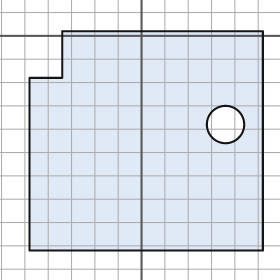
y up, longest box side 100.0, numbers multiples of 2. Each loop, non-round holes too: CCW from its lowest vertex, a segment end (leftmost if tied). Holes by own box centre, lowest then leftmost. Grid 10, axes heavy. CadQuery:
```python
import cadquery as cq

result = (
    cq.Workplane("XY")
    .moveTo(-48.0, -92.0)
    .lineTo(52.0, -92.0)
    .lineTo(52.0, 2.0)
    .lineTo(-34.0, 2.0)
    .lineTo(-34.0, -18.0)
    .lineTo(-48.0, -18.0)
    .close()
    .moveTo(36.0, -38.0)
    .circle(8.0)
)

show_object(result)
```